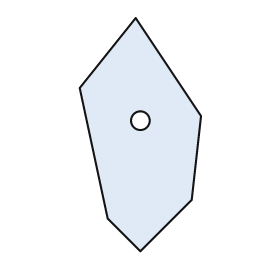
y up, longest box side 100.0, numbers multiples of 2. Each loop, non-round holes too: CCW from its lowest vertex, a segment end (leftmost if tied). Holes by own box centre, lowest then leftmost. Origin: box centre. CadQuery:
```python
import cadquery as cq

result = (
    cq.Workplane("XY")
    .moveTo(0.0, -50.0)
    .lineTo(22.0, -28.0)
    .lineTo(26.0, 8.0)
    .lineTo(-2.0, 50.0)
    .lineTo(-26.0, 20.0)
    .lineTo(-14.0, -36.0)
    .close()
    .moveTo(0.0, 6.0)
    .circle(4.0)
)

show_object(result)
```